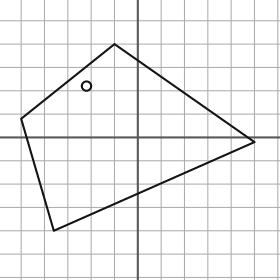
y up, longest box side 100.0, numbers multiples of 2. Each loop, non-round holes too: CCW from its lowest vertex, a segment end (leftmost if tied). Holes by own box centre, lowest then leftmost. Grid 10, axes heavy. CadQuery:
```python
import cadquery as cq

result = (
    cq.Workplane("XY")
    .moveTo(-36.0, -40.0)
    .lineTo(50.0, -2.0)
    .lineTo(-10.0, 40.0)
    .lineTo(-50.0, 8.0)
    .close()
    .moveTo(-22.0, 22.0)
    .circle(2.0)
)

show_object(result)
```